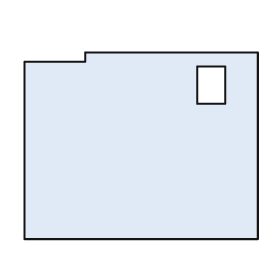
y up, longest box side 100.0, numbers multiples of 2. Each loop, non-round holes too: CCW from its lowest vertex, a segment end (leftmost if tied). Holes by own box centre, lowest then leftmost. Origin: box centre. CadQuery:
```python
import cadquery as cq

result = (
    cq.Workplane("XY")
    .moveTo(-50.0, -40.0)
    .lineTo(50.0, -40.0)
    .lineTo(50.0, 40.0)
    .lineTo(-24.0, 40.0)
    .lineTo(-24.0, 36.0)
    .lineTo(-50.0, 36.0)
    .close()
    .moveTo(24.0, 18.0)
    .lineTo(36.0, 18.0)
    .lineTo(36.0, 34.0)
    .lineTo(24.0, 34.0)
    .close()
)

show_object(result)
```